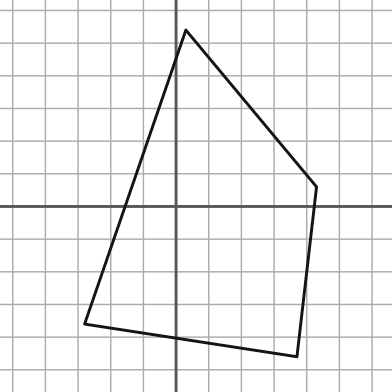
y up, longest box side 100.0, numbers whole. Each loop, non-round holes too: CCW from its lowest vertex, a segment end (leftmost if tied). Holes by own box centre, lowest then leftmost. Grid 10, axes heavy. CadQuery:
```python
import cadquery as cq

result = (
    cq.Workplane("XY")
    .moveTo(37.0, -46.0)
    .lineTo(43.0, 6.0)
    .lineTo(3.0, 54.0)
    .lineTo(-28.0, -36.0)
    .close()
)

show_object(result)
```